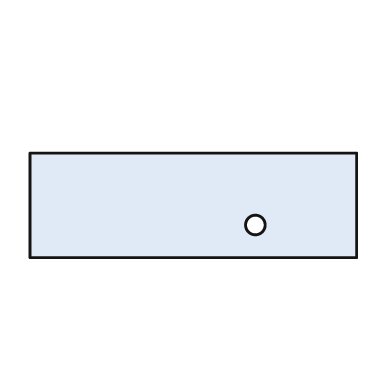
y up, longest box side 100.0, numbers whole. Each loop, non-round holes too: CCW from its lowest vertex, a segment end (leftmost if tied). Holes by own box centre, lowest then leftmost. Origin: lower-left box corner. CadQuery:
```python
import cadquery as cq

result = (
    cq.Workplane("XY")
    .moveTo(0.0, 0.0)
    .lineTo(100.0, 0.0)
    .lineTo(100.0, 32.0)
    .lineTo(0.0, 32.0)
    .close()
    .moveTo(69.0, 10.0)
    .circle(3.0)
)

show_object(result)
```